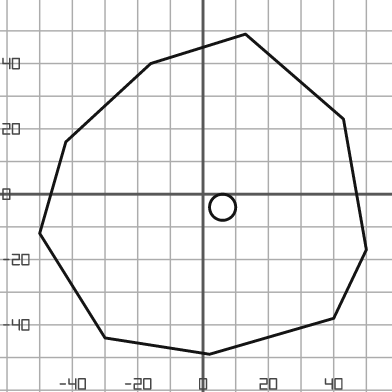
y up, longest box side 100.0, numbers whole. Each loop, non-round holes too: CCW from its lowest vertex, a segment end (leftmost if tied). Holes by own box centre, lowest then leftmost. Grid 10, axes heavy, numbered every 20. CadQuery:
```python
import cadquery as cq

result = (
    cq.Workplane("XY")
    .moveTo(2.0, -49.0)
    .lineTo(40.0, -38.0)
    .lineTo(50.0, -17.0)
    .lineTo(43.0, 23.0)
    .lineTo(13.0, 49.0)
    .lineTo(-16.0, 40.0)
    .lineTo(-42.0, 16.0)
    .lineTo(-50.0, -12.0)
    .lineTo(-30.0, -44.0)
    .close()
    .moveTo(6.0, -4.0)
    .circle(4.0)
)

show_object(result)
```